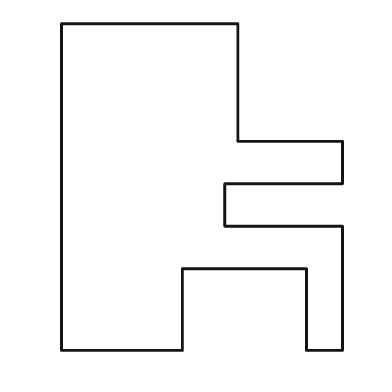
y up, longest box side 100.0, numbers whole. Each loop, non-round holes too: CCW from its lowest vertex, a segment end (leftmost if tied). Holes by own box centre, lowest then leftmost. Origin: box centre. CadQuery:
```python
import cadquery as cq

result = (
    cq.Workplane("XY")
    .moveTo(-43.0, -50.0)
    .lineTo(-6.0, -50.0)
    .lineTo(-6.0, -25.0)
    .lineTo(32.0, -25.0)
    .lineTo(32.0, -50.0)
    .lineTo(43.0, -50.0)
    .lineTo(43.0, -12.0)
    .lineTo(7.0, -12.0)
    .lineTo(7.0, 1.0)
    .lineTo(43.0, 1.0)
    .lineTo(43.0, 14.0)
    .lineTo(11.0, 14.0)
    .lineTo(11.0, 50.0)
    .lineTo(-43.0, 50.0)
    .close()
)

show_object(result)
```